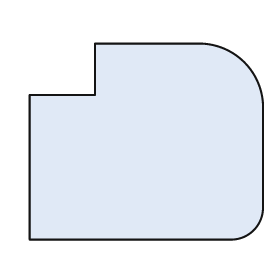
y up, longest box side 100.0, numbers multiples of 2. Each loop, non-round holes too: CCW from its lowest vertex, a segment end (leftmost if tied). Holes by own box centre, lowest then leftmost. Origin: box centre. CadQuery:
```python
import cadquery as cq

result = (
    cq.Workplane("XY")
    .moveTo(-50.0, -42.0)
    .lineTo(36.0, -42.0)
    .threePointArc((46.0, -38.0), (50.0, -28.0))
    .lineTo(50.0, 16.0)
    .threePointArc((42.0, 34.0), (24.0, 42.0))
    .lineTo(-22.0, 42.0)
    .lineTo(-22.0, 20.0)
    .lineTo(-50.0, 20.0)
    .close()
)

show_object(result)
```